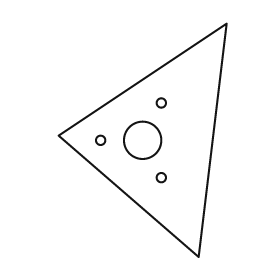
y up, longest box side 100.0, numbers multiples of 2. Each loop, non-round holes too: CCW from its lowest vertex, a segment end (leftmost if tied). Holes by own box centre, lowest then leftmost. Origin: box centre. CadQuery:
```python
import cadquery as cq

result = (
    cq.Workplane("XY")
    .moveTo(24.0, -50.0)
    .lineTo(36.0, 50.0)
    .lineTo(-36.0, 2.0)
    .close()
    .moveTo(8.0, -16.0)
    .circle(2.0)
    .moveTo(-18.0, 0.0)
    .circle(2.0)
    .moveTo(0.0, 0.0)
    .circle(8.0)
    .moveTo(8.0, 16.0)
    .circle(2.0)
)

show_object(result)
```